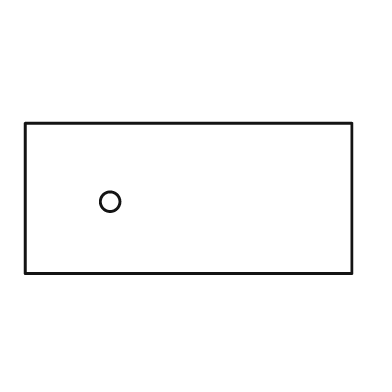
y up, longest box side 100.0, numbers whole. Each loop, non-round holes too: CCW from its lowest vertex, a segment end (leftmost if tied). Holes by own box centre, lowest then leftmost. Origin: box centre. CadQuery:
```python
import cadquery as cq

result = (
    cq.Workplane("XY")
    .moveTo(-50.0, -23.0)
    .lineTo(50.0, -23.0)
    .lineTo(50.0, 23.0)
    .lineTo(-50.0, 23.0)
    .close()
    .moveTo(-24.0, -1.0)
    .circle(3.0)
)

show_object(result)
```